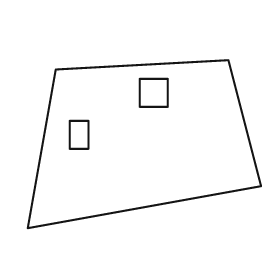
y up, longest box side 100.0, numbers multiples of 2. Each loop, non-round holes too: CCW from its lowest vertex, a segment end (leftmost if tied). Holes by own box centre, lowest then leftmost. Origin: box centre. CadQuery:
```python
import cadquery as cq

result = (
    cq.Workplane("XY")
    .moveTo(-50.0, -36.0)
    .lineTo(50.0, -18.0)
    .lineTo(36.0, 36.0)
    .lineTo(-38.0, 32.0)
    .close()
    .moveTo(-32.0, -2.0)
    .lineTo(-24.0, -2.0)
    .lineTo(-24.0, 10.0)
    .lineTo(-32.0, 10.0)
    .close()
    .moveTo(-2.0, 16.0)
    .lineTo(10.0, 16.0)
    .lineTo(10.0, 28.0)
    .lineTo(-2.0, 28.0)
    .close()
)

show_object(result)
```